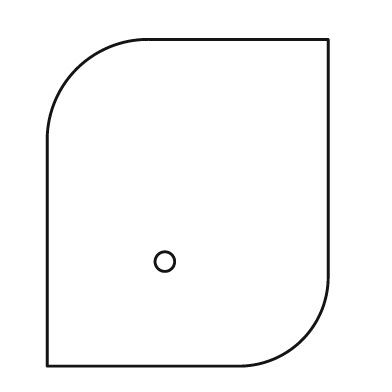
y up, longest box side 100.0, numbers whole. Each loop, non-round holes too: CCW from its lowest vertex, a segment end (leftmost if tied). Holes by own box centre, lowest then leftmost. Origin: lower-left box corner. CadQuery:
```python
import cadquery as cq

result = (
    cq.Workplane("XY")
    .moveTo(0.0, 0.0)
    .lineTo(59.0, 0.0)
    .threePointArc((78.0, 8.0), (86.0, 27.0))
    .lineTo(86.0, 100.0)
    .lineTo(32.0, 100.0)
    .threePointArc((9.0, 91.0), (0.0, 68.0))
    .close()
    .moveTo(36.0, 32.0)
    .circle(3.0)
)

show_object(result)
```